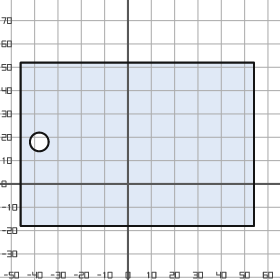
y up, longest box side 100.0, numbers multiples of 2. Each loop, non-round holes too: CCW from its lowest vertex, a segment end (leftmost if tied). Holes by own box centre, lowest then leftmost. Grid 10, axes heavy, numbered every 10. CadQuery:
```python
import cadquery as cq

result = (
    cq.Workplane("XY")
    .moveTo(-46.0, -18.0)
    .lineTo(54.0, -18.0)
    .lineTo(54.0, 52.0)
    .lineTo(-46.0, 52.0)
    .close()
    .moveTo(-38.0, 18.0)
    .circle(4.0)
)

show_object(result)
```